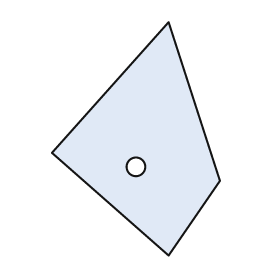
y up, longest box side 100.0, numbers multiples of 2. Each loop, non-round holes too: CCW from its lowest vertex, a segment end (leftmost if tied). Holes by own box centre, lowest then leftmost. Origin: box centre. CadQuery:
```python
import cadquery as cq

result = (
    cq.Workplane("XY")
    .moveTo(14.0, -50.0)
    .lineTo(36.0, -18.0)
    .lineTo(14.0, 50.0)
    .lineTo(-36.0, -6.0)
    .close()
    .moveTo(0.0, -12.0)
    .circle(4.0)
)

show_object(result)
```